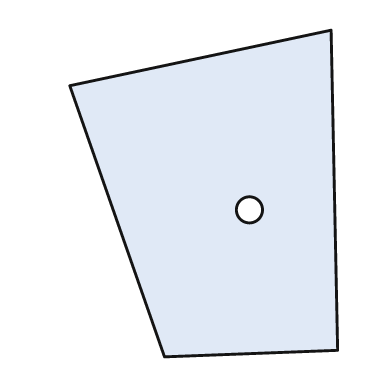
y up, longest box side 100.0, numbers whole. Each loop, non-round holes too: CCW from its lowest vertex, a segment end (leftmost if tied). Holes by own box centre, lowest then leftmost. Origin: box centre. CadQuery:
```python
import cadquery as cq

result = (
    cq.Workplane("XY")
    .moveTo(-12.0, -50.0)
    .lineTo(41.0, -48.0)
    .lineTo(39.0, 50.0)
    .lineTo(-41.0, 33.0)
    .close()
    .moveTo(14.0, -5.0)
    .circle(4.0)
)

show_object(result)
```